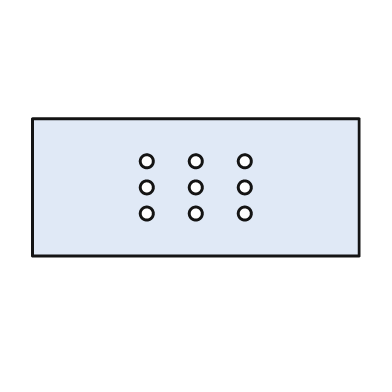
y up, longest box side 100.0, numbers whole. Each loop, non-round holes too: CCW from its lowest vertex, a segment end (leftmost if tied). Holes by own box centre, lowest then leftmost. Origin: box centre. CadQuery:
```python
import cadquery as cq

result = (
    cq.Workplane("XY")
    .moveTo(-50.0, -21.0)
    .lineTo(50.0, -21.0)
    .lineTo(50.0, 21.0)
    .lineTo(-50.0, 21.0)
    .close()
    .moveTo(-15.0, -8.0)
    .circle(2.0)
    .moveTo(0.0, -8.0)
    .circle(2.0)
    .moveTo(15.0, -8.0)
    .circle(2.0)
    .moveTo(-15.0, 0.0)
    .circle(2.0)
    .moveTo(0.0, 0.0)
    .circle(2.0)
    .moveTo(15.0, 0.0)
    .circle(2.0)
    .moveTo(-15.0, 8.0)
    .circle(2.0)
    .moveTo(0.0, 8.0)
    .circle(2.0)
    .moveTo(15.0, 8.0)
    .circle(2.0)
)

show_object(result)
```